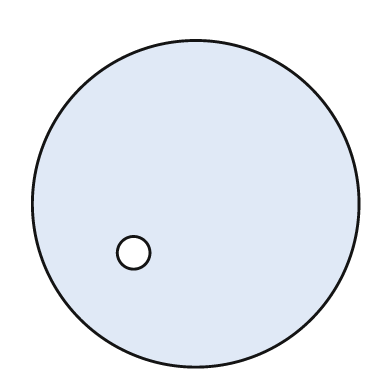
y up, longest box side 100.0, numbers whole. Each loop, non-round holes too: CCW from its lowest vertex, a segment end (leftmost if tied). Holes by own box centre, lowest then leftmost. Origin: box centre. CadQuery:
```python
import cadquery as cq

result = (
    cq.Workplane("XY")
    .moveTo(0.0, 0.0)
    .circle(50.0)
    .moveTo(-19.0, -15.0)
    .circle(5.0)
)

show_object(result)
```